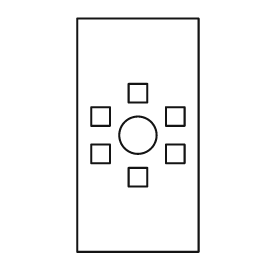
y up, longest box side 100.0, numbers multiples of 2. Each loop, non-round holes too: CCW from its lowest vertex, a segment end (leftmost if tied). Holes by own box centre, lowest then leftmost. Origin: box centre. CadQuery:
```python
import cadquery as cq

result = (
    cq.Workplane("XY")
    .moveTo(-26.0, -50.0)
    .lineTo(26.0, -50.0)
    .lineTo(26.0, 50.0)
    .lineTo(-26.0, 50.0)
    .close()
    .moveTo(-4.0, -22.0)
    .lineTo(4.0, -22.0)
    .lineTo(4.0, -14.0)
    .lineTo(-4.0, -14.0)
    .close()
    .moveTo(-20.0, -12.0)
    .lineTo(-12.0, -12.0)
    .lineTo(-12.0, -4.0)
    .lineTo(-20.0, -4.0)
    .close()
    .moveTo(12.0, -12.0)
    .lineTo(20.0, -12.0)
    .lineTo(20.0, -4.0)
    .lineTo(12.0, -4.0)
    .close()
    .moveTo(0.0, 0.0)
    .circle(8.0)
    .moveTo(-20.0, 4.0)
    .lineTo(-12.0, 4.0)
    .lineTo(-12.0, 12.0)
    .lineTo(-20.0, 12.0)
    .close()
    .moveTo(12.0, 4.0)
    .lineTo(20.0, 4.0)
    .lineTo(20.0, 12.0)
    .lineTo(12.0, 12.0)
    .close()
    .moveTo(-4.0, 14.0)
    .lineTo(4.0, 14.0)
    .lineTo(4.0, 22.0)
    .lineTo(-4.0, 22.0)
    .close()
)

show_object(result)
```